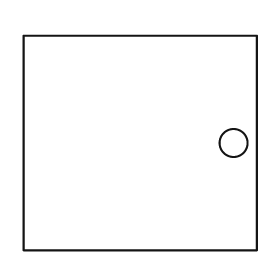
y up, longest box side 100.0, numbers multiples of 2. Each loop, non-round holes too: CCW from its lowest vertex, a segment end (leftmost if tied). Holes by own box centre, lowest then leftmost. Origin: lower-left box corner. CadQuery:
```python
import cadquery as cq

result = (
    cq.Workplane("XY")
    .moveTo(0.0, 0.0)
    .lineTo(100.0, 0.0)
    .lineTo(100.0, 92.0)
    .lineTo(0.0, 92.0)
    .close()
    .moveTo(90.0, 46.0)
    .circle(6.0)
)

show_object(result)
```